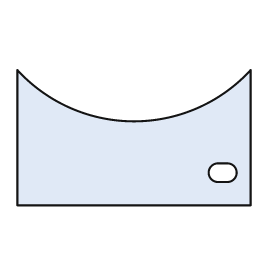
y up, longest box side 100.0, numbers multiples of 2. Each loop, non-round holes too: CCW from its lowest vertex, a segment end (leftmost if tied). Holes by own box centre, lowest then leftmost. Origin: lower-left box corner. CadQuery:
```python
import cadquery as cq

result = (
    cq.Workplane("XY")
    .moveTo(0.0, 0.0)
    .lineTo(100.0, 0.0)
    .lineTo(100.0, 58.0)
    .threePointArc((50.0, 36.0), (0.0, 58.0))
    .close()
    .moveTo(86.0, 10.0)
    .lineTo(90.0, 10.0)
    .threePointArc((94.0, 14.0), (90.0, 18.0))
    .lineTo(86.0, 18.0)
    .threePointArc((82.0, 14.0), (86.0, 10.0))
    .close()
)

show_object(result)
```